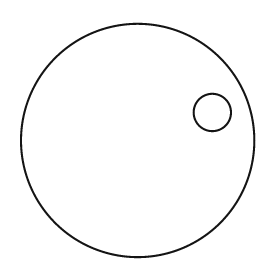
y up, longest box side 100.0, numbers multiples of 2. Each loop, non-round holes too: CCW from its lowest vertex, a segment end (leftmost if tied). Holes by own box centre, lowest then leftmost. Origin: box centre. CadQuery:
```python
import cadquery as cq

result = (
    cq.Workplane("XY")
    .moveTo(0.0, 0.0)
    .circle(50.0)
    .moveTo(32.0, 12.0)
    .circle(8.0)
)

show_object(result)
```